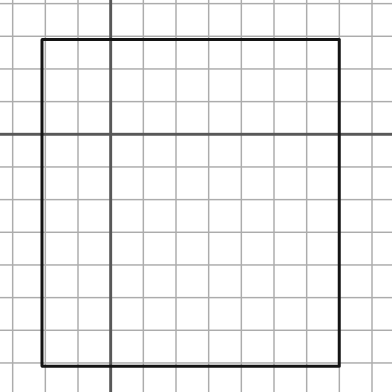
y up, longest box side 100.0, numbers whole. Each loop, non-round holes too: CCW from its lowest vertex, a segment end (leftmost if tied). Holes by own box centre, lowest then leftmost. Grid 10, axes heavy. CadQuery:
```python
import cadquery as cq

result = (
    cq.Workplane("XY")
    .moveTo(-21.0, -71.0)
    .lineTo(70.0, -71.0)
    .lineTo(70.0, 29.0)
    .lineTo(-21.0, 29.0)
    .close()
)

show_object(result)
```